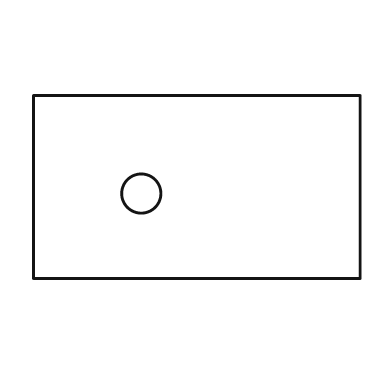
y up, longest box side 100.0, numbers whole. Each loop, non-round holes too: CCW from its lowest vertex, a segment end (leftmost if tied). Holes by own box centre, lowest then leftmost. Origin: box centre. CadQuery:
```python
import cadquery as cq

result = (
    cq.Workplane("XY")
    .moveTo(-50.0, -28.0)
    .lineTo(50.0, -28.0)
    .lineTo(50.0, 28.0)
    .lineTo(-50.0, 28.0)
    .close()
    .moveTo(-17.0, -2.0)
    .circle(6.0)
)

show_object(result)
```